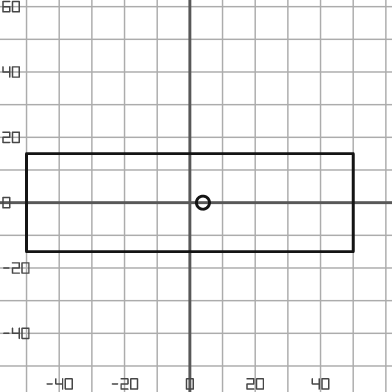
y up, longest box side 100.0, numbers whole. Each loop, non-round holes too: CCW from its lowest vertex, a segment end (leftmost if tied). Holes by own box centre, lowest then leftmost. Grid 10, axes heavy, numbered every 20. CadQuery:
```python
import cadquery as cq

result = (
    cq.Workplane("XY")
    .moveTo(-50.0, -15.0)
    .lineTo(50.0, -15.0)
    .lineTo(50.0, 15.0)
    .lineTo(-50.0, 15.0)
    .close()
    .moveTo(4.0, 0.0)
    .circle(2.0)
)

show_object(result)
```